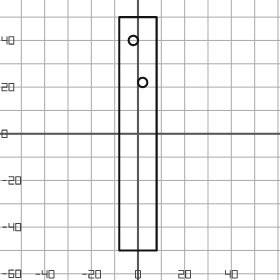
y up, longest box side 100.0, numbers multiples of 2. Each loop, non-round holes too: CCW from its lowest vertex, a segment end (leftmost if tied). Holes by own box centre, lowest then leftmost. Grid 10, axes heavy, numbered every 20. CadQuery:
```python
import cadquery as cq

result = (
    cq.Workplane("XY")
    .moveTo(-8.0, -50.0)
    .lineTo(8.0, -50.0)
    .lineTo(8.0, 50.0)
    .lineTo(-8.0, 50.0)
    .close()
    .moveTo(2.0, 22.0)
    .circle(2.0)
    .moveTo(-2.0, 40.0)
    .circle(2.0)
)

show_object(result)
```